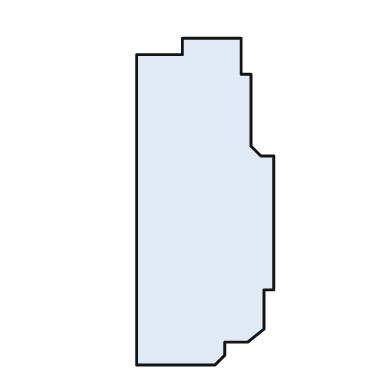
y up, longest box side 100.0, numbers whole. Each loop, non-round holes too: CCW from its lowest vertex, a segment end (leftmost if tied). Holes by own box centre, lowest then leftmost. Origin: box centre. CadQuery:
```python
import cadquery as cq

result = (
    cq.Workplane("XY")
    .moveTo(-21.0, -50.0)
    .lineTo(3.0, -50.0)
    .lineTo(6.0, -47.0)
    .lineTo(6.0, -43.0)
    .lineTo(13.0, -43.0)
    .lineTo(18.0, -39.0)
    .lineTo(18.0, -27.0)
    .lineTo(21.0, -27.0)
    .lineTo(21.0, 14.0)
    .lineTo(17.0, 14.0)
    .lineTo(14.0, 17.0)
    .lineTo(14.0, 39.0)
    .lineTo(11.0, 39.0)
    .lineTo(11.0, 50.0)
    .lineTo(-7.0, 50.0)
    .lineTo(-7.0, 45.0)
    .lineTo(-21.0, 45.0)
    .close()
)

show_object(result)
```